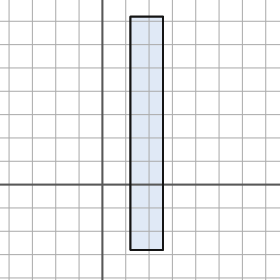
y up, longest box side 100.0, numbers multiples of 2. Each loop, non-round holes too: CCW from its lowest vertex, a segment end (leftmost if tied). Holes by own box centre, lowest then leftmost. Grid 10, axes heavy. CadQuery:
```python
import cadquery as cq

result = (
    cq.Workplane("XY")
    .moveTo(12.0, -28.0)
    .lineTo(26.0, -28.0)
    .lineTo(26.0, 72.0)
    .lineTo(12.0, 72.0)
    .close()
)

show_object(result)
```